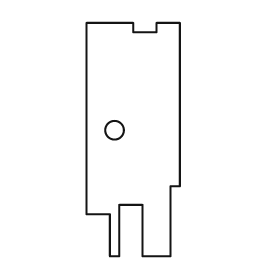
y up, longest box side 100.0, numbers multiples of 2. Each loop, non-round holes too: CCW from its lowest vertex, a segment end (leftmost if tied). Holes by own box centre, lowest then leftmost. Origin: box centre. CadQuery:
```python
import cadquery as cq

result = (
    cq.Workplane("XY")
    .moveTo(-10.0, -50.0)
    .lineTo(-6.0, -50.0)
    .lineTo(-6.0, -28.0)
    .lineTo(4.0, -28.0)
    .lineTo(4.0, -50.0)
    .lineTo(16.0, -50.0)
    .lineTo(16.0, -20.0)
    .lineTo(20.0, -20.0)
    .lineTo(20.0, 50.0)
    .lineTo(10.0, 50.0)
    .lineTo(10.0, 46.0)
    .lineTo(0.0, 46.0)
    .lineTo(0.0, 50.0)
    .lineTo(-20.0, 50.0)
    .lineTo(-20.0, -32.0)
    .lineTo(-10.0, -32.0)
    .close()
    .moveTo(-8.0, 4.0)
    .circle(4.0)
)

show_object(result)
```